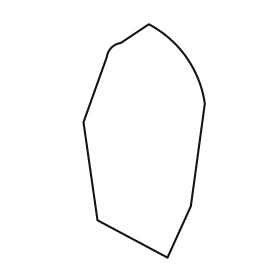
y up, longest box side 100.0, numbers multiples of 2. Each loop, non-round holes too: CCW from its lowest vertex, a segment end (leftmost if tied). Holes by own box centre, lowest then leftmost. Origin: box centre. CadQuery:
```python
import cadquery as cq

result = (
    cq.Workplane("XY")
    .moveTo(10.0, -50.0)
    .lineTo(20.0, -28.0)
    .lineTo(26.0, 16.0)
    .threePointArc((18.0, 36.0), (2.0, 50.0))
    .lineTo(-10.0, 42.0)
    .threePointArc((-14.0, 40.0), (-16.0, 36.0))
    .lineTo(-26.0, 8.0)
    .lineTo(-20.0, -34.0)
    .close()
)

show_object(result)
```